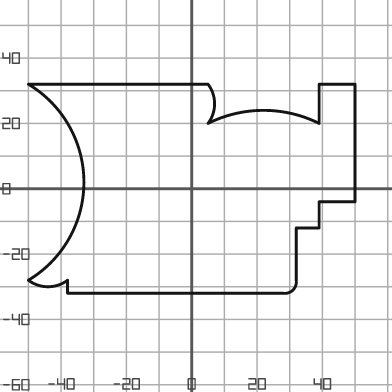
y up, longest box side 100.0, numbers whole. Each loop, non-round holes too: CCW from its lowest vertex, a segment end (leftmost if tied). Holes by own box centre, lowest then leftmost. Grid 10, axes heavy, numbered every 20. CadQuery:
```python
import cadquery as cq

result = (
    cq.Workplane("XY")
    .moveTo(-38.0, -32.0)
    .lineTo(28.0, -32.0)
    .threePointArc((31.0, -31.0), (32.0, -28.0))
    .lineTo(32.0, -12.0)
    .lineTo(39.0, -12.0)
    .lineTo(39.0, -4.0)
    .lineTo(50.0, -4.0)
    .lineTo(50.0, 32.0)
    .lineTo(39.0, 32.0)
    .lineTo(39.0, 20.0)
    .threePointArc((22.0, 24.0), (5.0, 20.0))
    .threePointArc((7.0, 26.0), (5.0, 32.0))
    .lineTo(-50.0, 32.0)
    .threePointArc((-33.0, 2.0), (-50.0, -28.0))
    .threePointArc((-44.0, -30.0), (-38.0, -28.0))
    .close()
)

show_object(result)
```